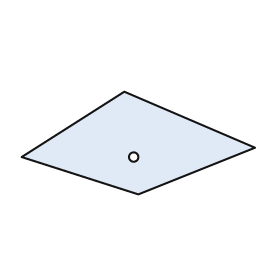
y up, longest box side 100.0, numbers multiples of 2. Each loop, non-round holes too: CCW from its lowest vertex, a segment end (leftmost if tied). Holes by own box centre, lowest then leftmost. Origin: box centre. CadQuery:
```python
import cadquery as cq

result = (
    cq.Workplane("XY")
    .moveTo(0.0, -22.0)
    .lineTo(50.0, -2.0)
    .lineTo(-6.0, 22.0)
    .lineTo(-50.0, -6.0)
    .close()
    .moveTo(-2.0, -6.0)
    .circle(2.0)
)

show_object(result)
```